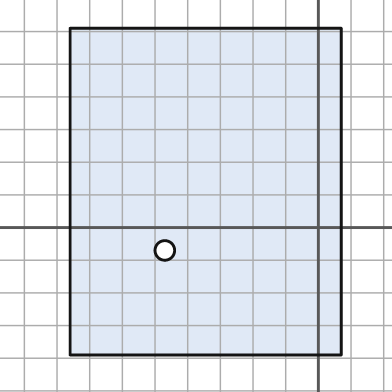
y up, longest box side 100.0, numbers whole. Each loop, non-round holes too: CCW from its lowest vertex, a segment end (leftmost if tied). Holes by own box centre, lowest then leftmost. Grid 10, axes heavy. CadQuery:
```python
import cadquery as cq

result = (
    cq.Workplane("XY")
    .moveTo(-76.0, -39.0)
    .lineTo(7.0, -39.0)
    .lineTo(7.0, 61.0)
    .lineTo(-76.0, 61.0)
    .close()
    .moveTo(-47.0, -7.0)
    .circle(3.0)
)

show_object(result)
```